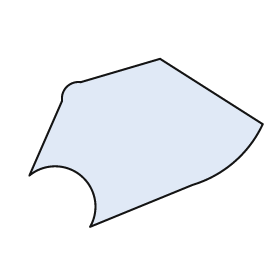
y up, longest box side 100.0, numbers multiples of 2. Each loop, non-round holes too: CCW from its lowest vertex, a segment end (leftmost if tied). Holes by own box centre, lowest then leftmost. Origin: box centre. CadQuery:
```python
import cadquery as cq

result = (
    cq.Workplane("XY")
    .moveTo(-24.0, -36.0)
    .lineTo(20.0, -18.0)
    .threePointArc((38.0, -8.0), (50.0, 8.0))
    .lineTo(6.0, 36.0)
    .lineTo(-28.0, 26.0)
    .threePointArc((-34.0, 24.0), (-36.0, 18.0))
    .lineTo(-50.0, -14.0)
    .threePointArc((-28.0, -14.0), (-24.0, -36.0))
    .close()
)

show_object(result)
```